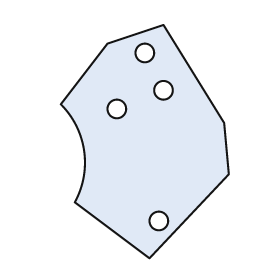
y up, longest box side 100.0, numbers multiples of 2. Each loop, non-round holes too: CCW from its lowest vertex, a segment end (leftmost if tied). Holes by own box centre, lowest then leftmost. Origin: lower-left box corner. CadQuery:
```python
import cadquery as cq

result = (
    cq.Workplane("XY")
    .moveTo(38.0, 0.0)
    .lineTo(72.0, 36.0)
    .lineTo(70.0, 58.0)
    .lineTo(44.0, 100.0)
    .lineTo(20.0, 92.0)
    .lineTo(0.0, 66.0)
    .threePointArc((10.0, 46.0), (6.0, 24.0))
    .close()
    .moveTo(42.0, 16.0)
    .circle(4.0)
    .moveTo(24.0, 64.0)
    .circle(4.0)
    .moveTo(44.0, 72.0)
    .circle(4.0)
    .moveTo(36.0, 88.0)
    .circle(4.0)
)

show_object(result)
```